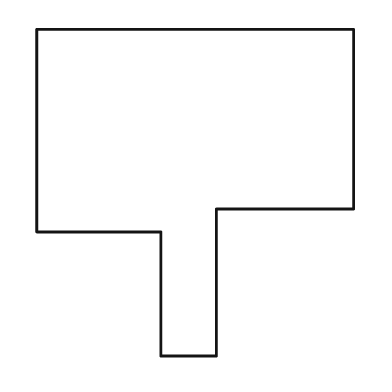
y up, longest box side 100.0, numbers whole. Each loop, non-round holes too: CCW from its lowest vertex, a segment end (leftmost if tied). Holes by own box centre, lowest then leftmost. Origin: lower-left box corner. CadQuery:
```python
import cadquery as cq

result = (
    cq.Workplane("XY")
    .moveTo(38.0, 0.0)
    .lineTo(55.0, 0.0)
    .lineTo(55.0, 45.0)
    .lineTo(97.0, 45.0)
    .lineTo(97.0, 100.0)
    .lineTo(0.0, 100.0)
    .lineTo(0.0, 38.0)
    .lineTo(38.0, 38.0)
    .close()
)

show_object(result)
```